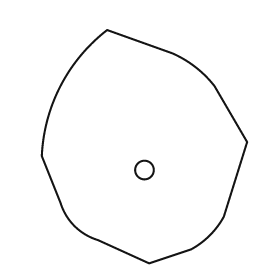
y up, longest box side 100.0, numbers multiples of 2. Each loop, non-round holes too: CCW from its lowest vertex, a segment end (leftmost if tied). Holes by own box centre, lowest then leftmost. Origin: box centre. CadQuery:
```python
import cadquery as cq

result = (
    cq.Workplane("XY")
    .moveTo(2.0, -50.0)
    .lineTo(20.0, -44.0)
    .threePointArc((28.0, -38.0), (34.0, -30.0))
    .lineTo(44.0, 2.0)
    .lineTo(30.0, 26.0)
    .threePointArc((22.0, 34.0), (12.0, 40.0))
    .lineTo(-16.0, 50.0)
    .threePointArc((-36.0, 26.0), (-44.0, -4.0))
    .lineTo(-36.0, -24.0)
    .threePointArc((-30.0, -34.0), (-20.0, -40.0))
    .close()
    .moveTo(0.0, -10.0)
    .circle(4.0)
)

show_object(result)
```